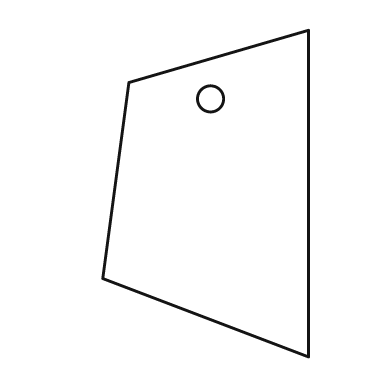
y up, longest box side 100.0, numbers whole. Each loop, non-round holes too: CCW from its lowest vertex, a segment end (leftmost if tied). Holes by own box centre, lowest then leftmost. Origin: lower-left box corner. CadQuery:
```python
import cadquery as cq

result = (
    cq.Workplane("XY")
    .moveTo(63.0, 0.0)
    .lineTo(63.0, 100.0)
    .lineTo(8.0, 84.0)
    .lineTo(0.0, 24.0)
    .close()
    .moveTo(33.0, 79.0)
    .circle(4.0)
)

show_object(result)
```